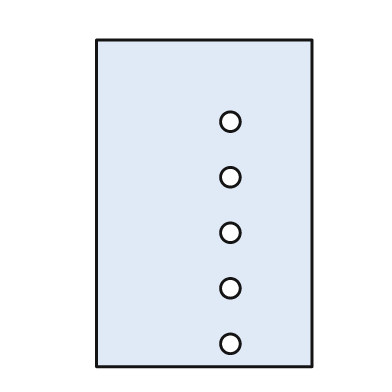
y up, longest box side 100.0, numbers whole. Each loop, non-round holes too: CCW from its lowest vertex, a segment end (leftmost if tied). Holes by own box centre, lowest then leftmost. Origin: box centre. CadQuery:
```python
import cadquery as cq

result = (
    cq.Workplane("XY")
    .moveTo(-33.0, -50.0)
    .lineTo(33.0, -50.0)
    .lineTo(33.0, 50.0)
    .lineTo(-33.0, 50.0)
    .close()
    .moveTo(8.0, -43.0)
    .circle(3.0)
    .moveTo(8.0, -26.0)
    .circle(3.0)
    .moveTo(8.0, -9.0)
    .circle(3.0)
    .moveTo(8.0, 8.0)
    .circle(3.0)
    .moveTo(8.0, 25.0)
    .circle(3.0)
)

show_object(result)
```